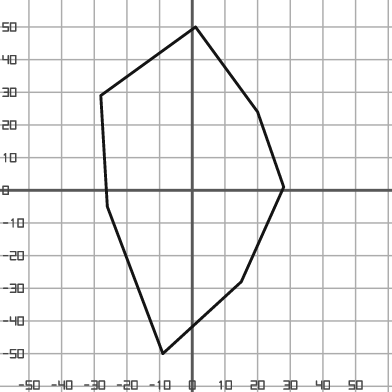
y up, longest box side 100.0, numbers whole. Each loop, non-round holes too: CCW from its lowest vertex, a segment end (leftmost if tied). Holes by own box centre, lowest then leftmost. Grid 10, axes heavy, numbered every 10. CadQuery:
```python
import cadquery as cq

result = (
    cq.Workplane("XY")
    .moveTo(-9.0, -50.0)
    .lineTo(15.0, -28.0)
    .lineTo(28.0, 1.0)
    .lineTo(20.0, 24.0)
    .lineTo(1.0, 50.0)
    .lineTo(-28.0, 29.0)
    .lineTo(-26.0, -5.0)
    .close()
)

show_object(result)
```